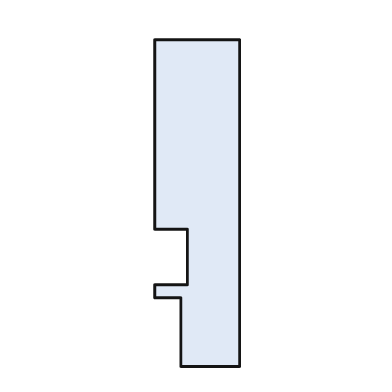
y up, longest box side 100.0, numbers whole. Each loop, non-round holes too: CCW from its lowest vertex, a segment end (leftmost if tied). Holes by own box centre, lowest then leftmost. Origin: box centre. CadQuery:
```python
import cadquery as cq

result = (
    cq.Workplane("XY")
    .moveTo(-5.0, -50.0)
    .lineTo(13.0, -50.0)
    .lineTo(13.0, 50.0)
    .lineTo(-13.0, 50.0)
    .lineTo(-13.0, -8.0)
    .lineTo(-3.0, -8.0)
    .lineTo(-3.0, -25.0)
    .lineTo(-13.0, -25.0)
    .lineTo(-13.0, -29.0)
    .lineTo(-5.0, -29.0)
    .close()
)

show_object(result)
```